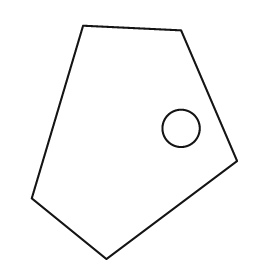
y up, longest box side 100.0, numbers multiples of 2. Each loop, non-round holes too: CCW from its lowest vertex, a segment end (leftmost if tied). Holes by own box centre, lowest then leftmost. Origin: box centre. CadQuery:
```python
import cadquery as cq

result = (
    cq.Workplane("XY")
    .moveTo(-12.0, -50.0)
    .lineTo(44.0, -8.0)
    .lineTo(20.0, 48.0)
    .lineTo(-22.0, 50.0)
    .lineTo(-44.0, -24.0)
    .close()
    .moveTo(20.0, 6.0)
    .circle(8.0)
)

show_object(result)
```